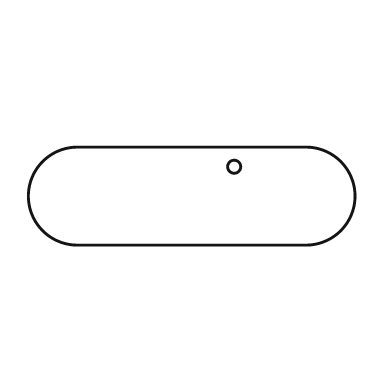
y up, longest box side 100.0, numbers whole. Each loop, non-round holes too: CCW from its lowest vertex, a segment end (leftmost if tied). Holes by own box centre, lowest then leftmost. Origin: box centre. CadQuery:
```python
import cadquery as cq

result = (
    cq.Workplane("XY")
    .moveTo(-35.0, -15.0)
    .lineTo(35.0, -15.0)
    .threePointArc((50.0, 0.0), (35.0, 15.0))
    .lineTo(-35.0, 15.0)
    .threePointArc((-50.0, 0.0), (-35.0, -15.0))
    .close()
    .moveTo(13.0, 9.0)
    .circle(2.0)
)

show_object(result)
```